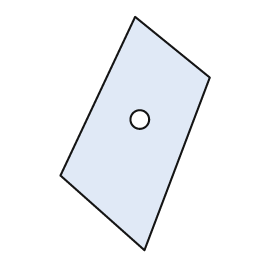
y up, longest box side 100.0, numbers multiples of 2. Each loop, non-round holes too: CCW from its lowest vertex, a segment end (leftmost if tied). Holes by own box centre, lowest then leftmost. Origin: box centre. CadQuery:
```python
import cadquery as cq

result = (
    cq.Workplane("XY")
    .moveTo(4.0, -50.0)
    .lineTo(32.0, 24.0)
    .lineTo(0.0, 50.0)
    .lineTo(-32.0, -18.0)
    .close()
    .moveTo(2.0, 6.0)
    .circle(4.0)
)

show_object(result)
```